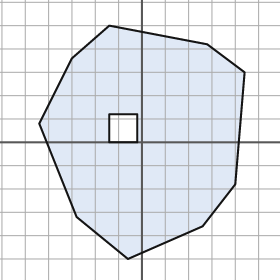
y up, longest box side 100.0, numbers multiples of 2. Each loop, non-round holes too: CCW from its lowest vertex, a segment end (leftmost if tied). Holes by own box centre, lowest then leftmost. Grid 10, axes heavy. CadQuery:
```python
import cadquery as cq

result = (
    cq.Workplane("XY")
    .moveTo(-6.0, -50.0)
    .lineTo(26.0, -36.0)
    .lineTo(40.0, -18.0)
    .lineTo(44.0, 30.0)
    .lineTo(28.0, 42.0)
    .lineTo(-14.0, 50.0)
    .lineTo(-30.0, 36.0)
    .lineTo(-44.0, 8.0)
    .lineTo(-28.0, -32.0)
    .close()
    .moveTo(-14.0, 0.0)
    .lineTo(-2.0, 0.0)
    .lineTo(-2.0, 12.0)
    .lineTo(-14.0, 12.0)
    .close()
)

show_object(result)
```